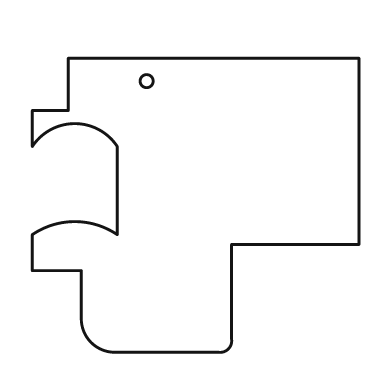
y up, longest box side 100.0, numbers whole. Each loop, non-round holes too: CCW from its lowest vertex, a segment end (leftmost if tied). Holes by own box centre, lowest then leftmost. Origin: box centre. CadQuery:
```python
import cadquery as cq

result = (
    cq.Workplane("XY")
    .moveTo(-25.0, -45.0)
    .lineTo(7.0, -45.0)
    .threePointArc((10.0, -44.0), (11.0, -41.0))
    .lineTo(11.0, -12.0)
    .lineTo(50.0, -12.0)
    .lineTo(50.0, 45.0)
    .lineTo(-39.0, 45.0)
    .lineTo(-39.0, 29.0)
    .lineTo(-50.0, 29.0)
    .lineTo(-50.0, 18.0)
    .threePointArc((-37.0, 25.0), (-24.0, 18.0))
    .lineTo(-24.0, -9.0)
    .threePointArc((-37.0, -5.0), (-50.0, -9.0))
    .lineTo(-50.0, -20.0)
    .lineTo(-35.0, -20.0)
    .lineTo(-35.0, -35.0)
    .threePointArc((-32.0, -42.0), (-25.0, -45.0))
    .close()
    .moveTo(-15.0, 38.0)
    .circle(2.0)
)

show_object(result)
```